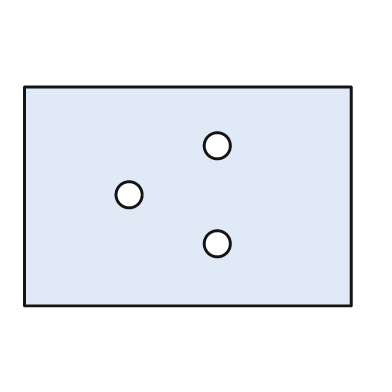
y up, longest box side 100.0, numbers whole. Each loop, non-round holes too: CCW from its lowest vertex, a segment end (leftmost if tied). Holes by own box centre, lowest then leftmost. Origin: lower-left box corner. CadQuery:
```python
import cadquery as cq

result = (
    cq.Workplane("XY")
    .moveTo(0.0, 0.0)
    .lineTo(100.0, 0.0)
    .lineTo(100.0, 67.0)
    .lineTo(0.0, 67.0)
    .close()
    .moveTo(59.0, 19.0)
    .circle(4.0)
    .moveTo(32.0, 34.0)
    .circle(4.0)
    .moveTo(59.0, 49.0)
    .circle(4.0)
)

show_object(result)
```